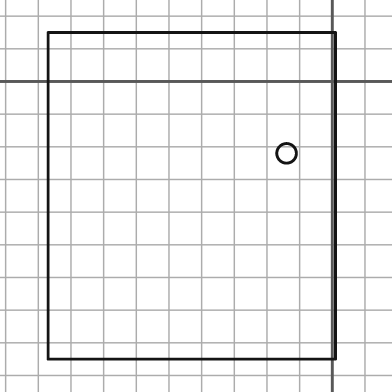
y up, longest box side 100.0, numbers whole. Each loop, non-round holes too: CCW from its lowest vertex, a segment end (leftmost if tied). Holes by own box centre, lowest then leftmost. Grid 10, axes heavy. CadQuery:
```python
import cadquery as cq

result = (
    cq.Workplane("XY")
    .moveTo(-87.0, -85.0)
    .lineTo(1.0, -85.0)
    .lineTo(1.0, 15.0)
    .lineTo(-87.0, 15.0)
    .close()
    .moveTo(-14.0, -22.0)
    .circle(3.0)
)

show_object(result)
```